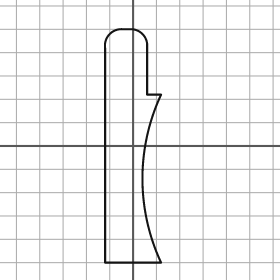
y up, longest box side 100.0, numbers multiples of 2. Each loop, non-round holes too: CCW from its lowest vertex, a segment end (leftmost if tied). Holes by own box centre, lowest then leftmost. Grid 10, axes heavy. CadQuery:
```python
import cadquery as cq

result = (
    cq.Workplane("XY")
    .moveTo(-12.0, -50.0)
    .lineTo(12.0, -50.0)
    .threePointArc((4.0, -14.0), (12.0, 22.0))
    .lineTo(6.0, 22.0)
    .lineTo(6.0, 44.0)
    .threePointArc((4.0, 48.0), (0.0, 50.0))
    .lineTo(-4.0, 50.0)
    .threePointArc((-10.0, 48.0), (-12.0, 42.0))
    .close()
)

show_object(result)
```